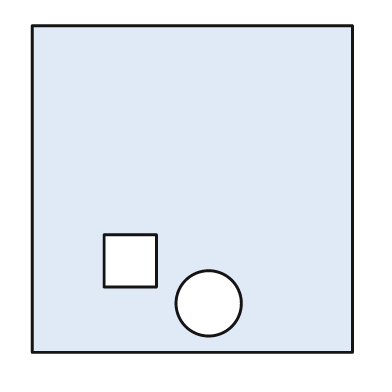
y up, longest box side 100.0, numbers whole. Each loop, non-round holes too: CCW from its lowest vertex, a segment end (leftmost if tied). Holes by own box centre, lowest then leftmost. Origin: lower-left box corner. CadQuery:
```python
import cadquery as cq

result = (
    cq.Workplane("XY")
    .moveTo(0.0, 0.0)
    .lineTo(98.0, 0.0)
    .lineTo(98.0, 100.0)
    .lineTo(0.0, 100.0)
    .close()
    .moveTo(54.0, 15.0)
    .circle(10.0)
    .moveTo(22.0, 20.0)
    .lineTo(38.0, 20.0)
    .lineTo(38.0, 36.0)
    .lineTo(22.0, 36.0)
    .close()
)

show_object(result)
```